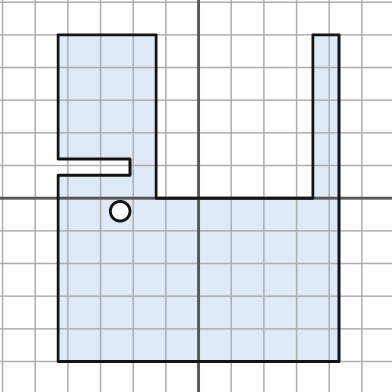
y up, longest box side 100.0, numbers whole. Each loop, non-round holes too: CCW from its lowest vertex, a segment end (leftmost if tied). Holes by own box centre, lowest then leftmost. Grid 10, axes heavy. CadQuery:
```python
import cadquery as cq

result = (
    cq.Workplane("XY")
    .moveTo(-43.0, -50.0)
    .lineTo(43.0, -50.0)
    .lineTo(43.0, 50.0)
    .lineTo(35.0, 50.0)
    .lineTo(35.0, 0.0)
    .lineTo(-13.0, 0.0)
    .lineTo(-13.0, 50.0)
    .lineTo(-43.0, 50.0)
    .lineTo(-43.0, 12.0)
    .lineTo(-21.0, 12.0)
    .lineTo(-21.0, 7.0)
    .lineTo(-43.0, 7.0)
    .close()
    .moveTo(-24.0, -4.0)
    .circle(3.0)
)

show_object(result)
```